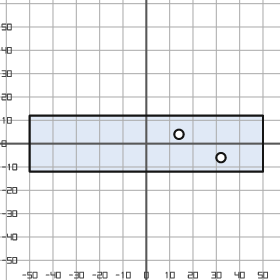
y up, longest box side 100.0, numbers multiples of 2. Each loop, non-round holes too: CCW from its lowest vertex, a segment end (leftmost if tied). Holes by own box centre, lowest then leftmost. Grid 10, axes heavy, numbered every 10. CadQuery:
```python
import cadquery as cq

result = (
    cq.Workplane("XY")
    .moveTo(-50.0, -12.0)
    .lineTo(50.0, -12.0)
    .lineTo(50.0, 12.0)
    .lineTo(-50.0, 12.0)
    .close()
    .moveTo(32.0, -6.0)
    .circle(2.0)
    .moveTo(14.0, 4.0)
    .circle(2.0)
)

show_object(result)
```